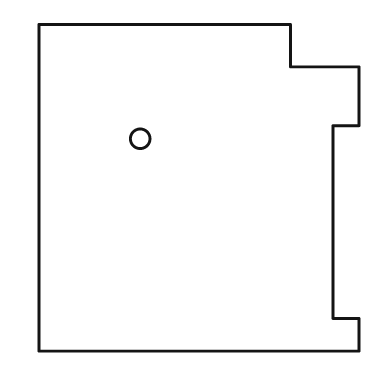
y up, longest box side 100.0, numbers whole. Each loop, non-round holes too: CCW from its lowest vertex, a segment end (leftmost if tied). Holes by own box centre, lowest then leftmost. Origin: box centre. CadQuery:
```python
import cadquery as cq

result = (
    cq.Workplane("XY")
    .moveTo(-49.0, -50.0)
    .lineTo(49.0, -50.0)
    .lineTo(49.0, -40.0)
    .lineTo(41.0, -40.0)
    .lineTo(41.0, 19.0)
    .lineTo(49.0, 19.0)
    .lineTo(49.0, 37.0)
    .lineTo(28.0, 37.0)
    .lineTo(28.0, 50.0)
    .lineTo(-49.0, 50.0)
    .close()
    .moveTo(-18.0, 15.0)
    .circle(3.0)
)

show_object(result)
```